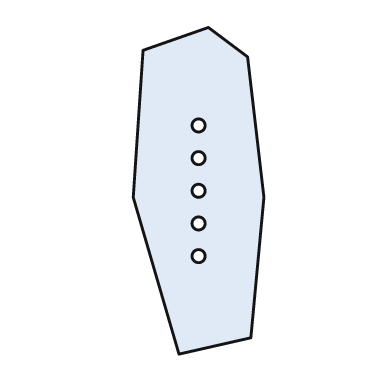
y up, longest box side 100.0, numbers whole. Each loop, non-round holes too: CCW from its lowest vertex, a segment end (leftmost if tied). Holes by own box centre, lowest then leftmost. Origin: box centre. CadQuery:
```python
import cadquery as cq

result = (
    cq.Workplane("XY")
    .moveTo(-6.0, -50.0)
    .lineTo(16.0, -45.0)
    .lineTo(20.0, -2.0)
    .lineTo(15.0, 41.0)
    .lineTo(3.0, 50.0)
    .lineTo(-17.0, 43.0)
    .lineTo(-20.0, -2.0)
    .close()
    .moveTo(0.0, -20.0)
    .circle(2.0)
    .moveTo(0.0, -10.0)
    .circle(2.0)
    .moveTo(0.0, 0.0)
    .circle(2.0)
    .moveTo(0.0, 10.0)
    .circle(2.0)
    .moveTo(0.0, 20.0)
    .circle(2.0)
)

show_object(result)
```